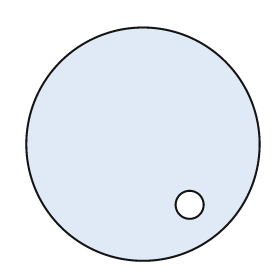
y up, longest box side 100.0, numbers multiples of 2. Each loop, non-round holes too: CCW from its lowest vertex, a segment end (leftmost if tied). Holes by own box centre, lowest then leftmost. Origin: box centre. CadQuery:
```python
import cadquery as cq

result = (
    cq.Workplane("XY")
    .moveTo(0.0, 0.0)
    .circle(50.0)
    .moveTo(20.0, -26.0)
    .circle(6.0)
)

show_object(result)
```